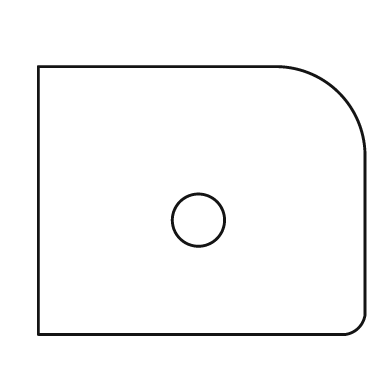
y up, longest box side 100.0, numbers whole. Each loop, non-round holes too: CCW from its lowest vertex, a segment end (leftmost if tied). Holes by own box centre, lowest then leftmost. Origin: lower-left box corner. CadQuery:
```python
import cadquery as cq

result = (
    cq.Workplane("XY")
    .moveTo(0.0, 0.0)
    .lineTo(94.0, 0.0)
    .threePointArc((98.0, 2.0), (100.0, 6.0))
    .lineTo(100.0, 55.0)
    .threePointArc((92.0, 74.0), (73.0, 82.0))
    .lineTo(0.0, 82.0)
    .close()
    .moveTo(49.0, 35.0)
    .circle(8.0)
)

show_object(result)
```